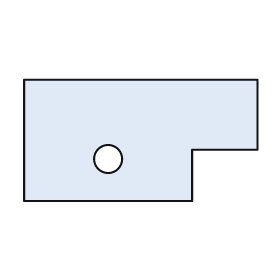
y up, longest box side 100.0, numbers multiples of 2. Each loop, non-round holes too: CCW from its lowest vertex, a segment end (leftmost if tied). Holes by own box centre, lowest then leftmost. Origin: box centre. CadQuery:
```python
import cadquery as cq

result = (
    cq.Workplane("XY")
    .moveTo(-50.0, -26.0)
    .lineTo(22.0, -26.0)
    .lineTo(22.0, -4.0)
    .lineTo(50.0, -4.0)
    .lineTo(50.0, 26.0)
    .lineTo(-50.0, 26.0)
    .close()
    .moveTo(-14.0, -8.0)
    .circle(6.0)
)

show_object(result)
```